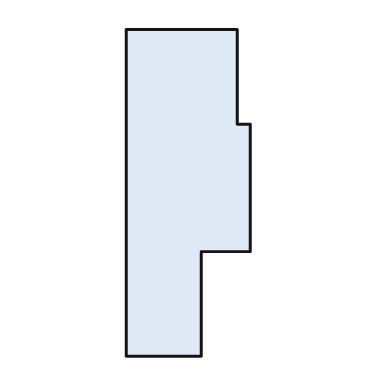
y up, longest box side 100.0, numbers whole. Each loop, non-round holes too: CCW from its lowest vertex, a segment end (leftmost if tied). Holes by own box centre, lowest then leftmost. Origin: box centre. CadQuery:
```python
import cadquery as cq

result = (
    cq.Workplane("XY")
    .moveTo(-19.0, -50.0)
    .lineTo(4.0, -50.0)
    .lineTo(4.0, -18.0)
    .lineTo(19.0, -18.0)
    .lineTo(19.0, 21.0)
    .lineTo(15.0, 21.0)
    .lineTo(15.0, 50.0)
    .lineTo(-19.0, 50.0)
    .close()
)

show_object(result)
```